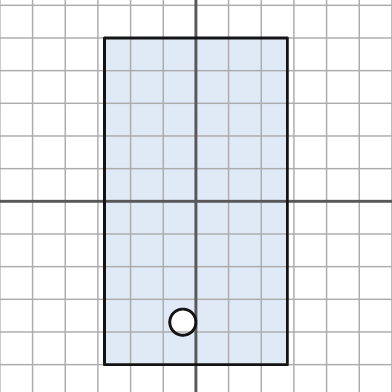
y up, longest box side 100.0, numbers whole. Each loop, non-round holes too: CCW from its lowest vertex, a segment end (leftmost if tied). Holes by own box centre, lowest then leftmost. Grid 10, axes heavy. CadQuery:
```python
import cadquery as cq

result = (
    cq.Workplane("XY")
    .moveTo(-28.0, -50.0)
    .lineTo(28.0, -50.0)
    .lineTo(28.0, 50.0)
    .lineTo(-28.0, 50.0)
    .close()
    .moveTo(-4.0, -37.0)
    .circle(4.0)
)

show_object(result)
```